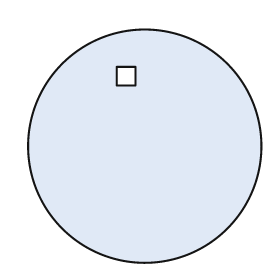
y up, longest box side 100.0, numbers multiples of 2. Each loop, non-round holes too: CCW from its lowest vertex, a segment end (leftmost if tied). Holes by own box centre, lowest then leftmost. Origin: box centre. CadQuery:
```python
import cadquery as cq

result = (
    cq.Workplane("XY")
    .moveTo(0.0, 0.0)
    .circle(50.0)
    .moveTo(-12.0, 26.0)
    .lineTo(-4.0, 26.0)
    .lineTo(-4.0, 34.0)
    .lineTo(-12.0, 34.0)
    .close()
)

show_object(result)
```